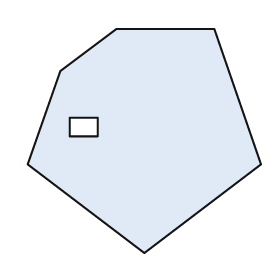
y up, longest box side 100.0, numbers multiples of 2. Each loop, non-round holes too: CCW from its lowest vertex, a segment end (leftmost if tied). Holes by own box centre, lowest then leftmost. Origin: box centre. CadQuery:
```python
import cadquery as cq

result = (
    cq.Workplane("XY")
    .moveTo(0.0, -48.0)
    .lineTo(50.0, -10.0)
    .lineTo(30.0, 48.0)
    .lineTo(-12.0, 48.0)
    .lineTo(-36.0, 30.0)
    .lineTo(-50.0, -10.0)
    .close()
    .moveTo(-32.0, 2.0)
    .lineTo(-20.0, 2.0)
    .lineTo(-20.0, 10.0)
    .lineTo(-32.0, 10.0)
    .close()
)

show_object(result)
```